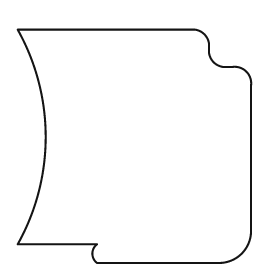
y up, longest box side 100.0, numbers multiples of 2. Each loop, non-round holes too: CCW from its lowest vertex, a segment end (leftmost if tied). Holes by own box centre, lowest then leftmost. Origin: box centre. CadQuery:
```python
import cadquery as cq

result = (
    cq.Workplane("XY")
    .moveTo(-16.0, -50.0)
    .lineTo(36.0, -50.0)
    .threePointArc((46.0, -46.0), (50.0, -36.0))
    .lineTo(50.0, 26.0)
    .threePointArc((48.0, 32.0), (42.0, 34.0))
    .lineTo(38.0, 34.0)
    .threePointArc((34.0, 36.0), (32.0, 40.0))
    .lineTo(32.0, 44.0)
    .threePointArc((30.0, 48.0), (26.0, 50.0))
    .lineTo(-50.0, 50.0)
    .threePointArc((-38.0, 4.0), (-50.0, -42.0))
    .lineTo(-16.0, -42.0)
    .threePointArc((-18.0, -46.0), (-16.0, -50.0))
    .close()
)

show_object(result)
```